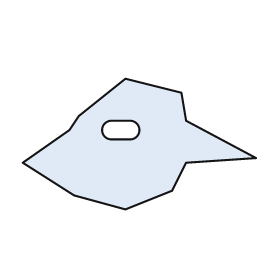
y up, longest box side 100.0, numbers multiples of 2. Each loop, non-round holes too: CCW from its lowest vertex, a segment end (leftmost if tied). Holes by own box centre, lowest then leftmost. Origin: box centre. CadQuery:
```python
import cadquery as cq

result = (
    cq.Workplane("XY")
    .moveTo(-6.0, -28.0)
    .lineTo(14.0, -20.0)
    .lineTo(20.0, -8.0)
    .lineTo(50.0, -6.0)
    .lineTo(20.0, 10.0)
    .lineTo(18.0, 22.0)
    .lineTo(-6.0, 28.0)
    .lineTo(-26.0, 12.0)
    .lineTo(-30.0, 6.0)
    .lineTo(-50.0, -8.0)
    .lineTo(-28.0, -22.0)
    .close()
    .moveTo(-12.0, 2.0)
    .lineTo(-4.0, 2.0)
    .threePointArc((0.0, 6.0), (-4.0, 10.0))
    .lineTo(-12.0, 10.0)
    .threePointArc((-16.0, 6.0), (-12.0, 2.0))
    .close()
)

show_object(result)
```